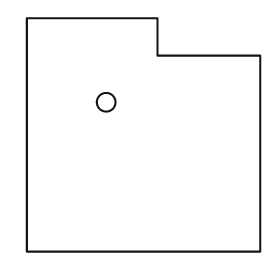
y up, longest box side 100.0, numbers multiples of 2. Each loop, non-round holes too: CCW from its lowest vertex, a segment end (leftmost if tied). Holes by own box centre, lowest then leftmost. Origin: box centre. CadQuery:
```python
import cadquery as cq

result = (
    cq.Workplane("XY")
    .moveTo(-50.0, -50.0)
    .lineTo(50.0, -50.0)
    .lineTo(50.0, 34.0)
    .lineTo(6.0, 34.0)
    .lineTo(6.0, 50.0)
    .lineTo(-50.0, 50.0)
    .close()
    .moveTo(-16.0, 14.0)
    .circle(4.0)
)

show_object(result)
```